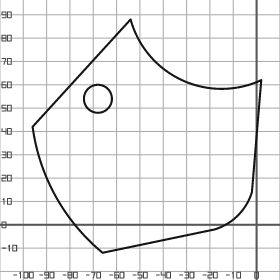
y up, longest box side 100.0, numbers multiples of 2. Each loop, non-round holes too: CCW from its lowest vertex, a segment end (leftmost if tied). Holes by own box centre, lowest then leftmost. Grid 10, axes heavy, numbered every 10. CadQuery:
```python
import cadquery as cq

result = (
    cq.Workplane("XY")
    .moveTo(-66.0, -12.0)
    .lineTo(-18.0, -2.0)
    .threePointArc((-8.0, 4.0), (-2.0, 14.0))
    .lineTo(2.0, 62.0)
    .threePointArc((-32.0, 62.0), (-54.0, 88.0))
    .lineTo(-96.0, 42.0)
    .threePointArc((-86.0, 12.0), (-66.0, -12.0))
    .close()
    .moveTo(-68.0, 54.0)
    .circle(6.0)
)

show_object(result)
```